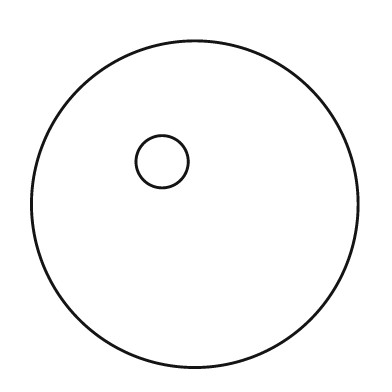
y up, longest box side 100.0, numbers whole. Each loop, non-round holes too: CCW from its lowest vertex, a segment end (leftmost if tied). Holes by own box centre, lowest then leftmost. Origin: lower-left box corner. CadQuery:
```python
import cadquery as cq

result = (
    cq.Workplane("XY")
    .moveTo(50.0, 50.0)
    .circle(50.0)
    .moveTo(40.0, 63.0)
    .circle(8.0)
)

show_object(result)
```